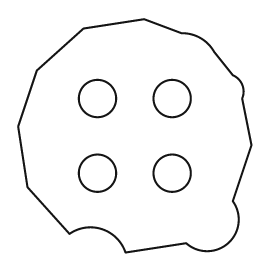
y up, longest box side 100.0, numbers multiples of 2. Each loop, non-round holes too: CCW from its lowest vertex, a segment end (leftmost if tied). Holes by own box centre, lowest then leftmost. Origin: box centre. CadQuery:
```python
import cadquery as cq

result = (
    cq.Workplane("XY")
    .moveTo(-4.0, -50.0)
    .lineTo(22.0, -46.0)
    .threePointArc((40.0, -46.0), (42.0, -28.0))
    .lineTo(50.0, -4.0)
    .lineTo(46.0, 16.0)
    .threePointArc((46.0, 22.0), (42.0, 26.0))
    .lineTo(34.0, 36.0)
    .threePointArc((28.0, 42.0), (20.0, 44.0))
    .lineTo(4.0, 50.0)
    .lineTo(-22.0, 46.0)
    .lineTo(-42.0, 28.0)
    .lineTo(-50.0, 4.0)
    .lineTo(-46.0, -22.0)
    .lineTo(-28.0, -42.0)
    .threePointArc((-14.0, -40.0), (-4.0, -50.0))
    .close()
    .moveTo(-16.0, -16.0)
    .circle(8.0)
    .moveTo(16.0, -16.0)
    .circle(8.0)
    .moveTo(-16.0, 16.0)
    .circle(8.0)
    .moveTo(16.0, 16.0)
    .circle(8.0)
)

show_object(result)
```